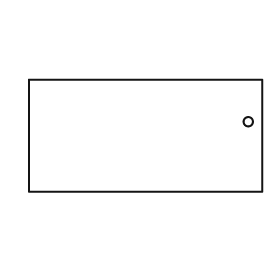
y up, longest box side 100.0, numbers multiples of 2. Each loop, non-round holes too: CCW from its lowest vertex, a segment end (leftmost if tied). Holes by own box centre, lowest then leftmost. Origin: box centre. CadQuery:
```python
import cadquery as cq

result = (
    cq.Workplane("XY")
    .moveTo(-50.0, -24.0)
    .lineTo(50.0, -24.0)
    .lineTo(50.0, 24.0)
    .lineTo(-50.0, 24.0)
    .close()
    .moveTo(44.0, 6.0)
    .circle(2.0)
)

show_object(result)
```